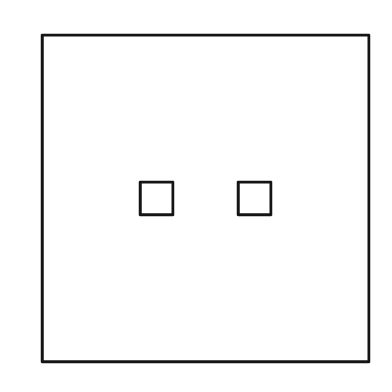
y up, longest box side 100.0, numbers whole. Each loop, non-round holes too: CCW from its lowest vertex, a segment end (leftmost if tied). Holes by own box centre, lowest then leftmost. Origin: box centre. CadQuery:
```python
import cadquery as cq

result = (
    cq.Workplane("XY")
    .moveTo(-50.0, -50.0)
    .lineTo(50.0, -50.0)
    .lineTo(50.0, 50.0)
    .lineTo(-50.0, 50.0)
    .close()
    .moveTo(-20.0, -5.0)
    .lineTo(-10.0, -5.0)
    .lineTo(-10.0, 5.0)
    .lineTo(-20.0, 5.0)
    .close()
    .moveTo(10.0, -5.0)
    .lineTo(20.0, -5.0)
    .lineTo(20.0, 5.0)
    .lineTo(10.0, 5.0)
    .close()
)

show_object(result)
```